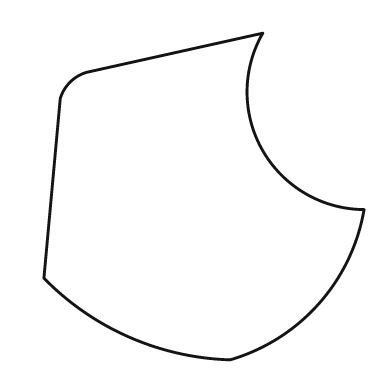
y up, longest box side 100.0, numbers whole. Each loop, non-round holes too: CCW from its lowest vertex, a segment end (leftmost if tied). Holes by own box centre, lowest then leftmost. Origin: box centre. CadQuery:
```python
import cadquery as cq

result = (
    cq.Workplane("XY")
    .moveTo(8.0, -50.0)
    .threePointArc((35.0, -33.0), (49.0, -4.0))
    .threePointArc((18.0, 14.0), (18.0, 50.0))
    .lineTo(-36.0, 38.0)
    .threePointArc((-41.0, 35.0), (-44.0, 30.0))
    .lineTo(-49.0, -25.0)
    .threePointArc((-23.0, -43.0), (8.0, -50.0))
    .close()
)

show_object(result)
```